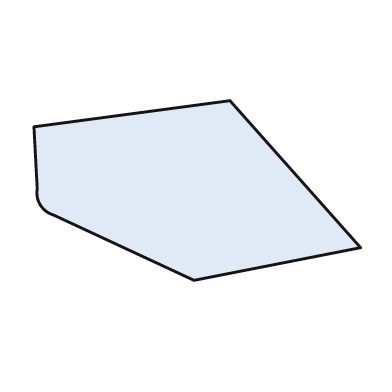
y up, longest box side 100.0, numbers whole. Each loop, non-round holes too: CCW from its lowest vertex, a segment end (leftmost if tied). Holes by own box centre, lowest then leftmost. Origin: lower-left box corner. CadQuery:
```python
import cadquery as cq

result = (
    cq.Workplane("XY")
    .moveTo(49.0, 0.0)
    .lineTo(100.0, 10.0)
    .lineTo(60.0, 55.0)
    .lineTo(0.0, 47.0)
    .lineTo(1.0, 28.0)
    .threePointArc((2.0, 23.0), (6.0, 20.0))
    .close()
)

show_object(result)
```